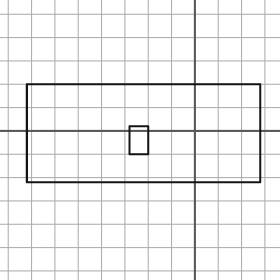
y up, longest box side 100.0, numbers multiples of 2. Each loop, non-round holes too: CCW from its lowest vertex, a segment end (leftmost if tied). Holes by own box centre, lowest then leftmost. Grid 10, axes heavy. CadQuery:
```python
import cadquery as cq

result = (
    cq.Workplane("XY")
    .moveTo(-72.0, -22.0)
    .lineTo(28.0, -22.0)
    .lineTo(28.0, 20.0)
    .lineTo(-72.0, 20.0)
    .close()
    .moveTo(-28.0, -10.0)
    .lineTo(-20.0, -10.0)
    .lineTo(-20.0, 2.0)
    .lineTo(-28.0, 2.0)
    .close()
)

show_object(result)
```